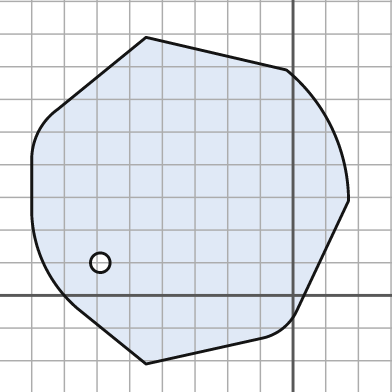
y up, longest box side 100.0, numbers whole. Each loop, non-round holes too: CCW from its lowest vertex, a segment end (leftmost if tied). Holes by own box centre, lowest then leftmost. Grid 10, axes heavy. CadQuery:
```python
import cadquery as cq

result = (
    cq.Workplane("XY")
    .moveTo(-45.0, -21.0)
    .lineTo(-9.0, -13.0)
    .threePointArc((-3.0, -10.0), (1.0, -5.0))
    .lineTo(17.0, 29.0)
    .threePointArc((12.0, 51.0), (-2.0, 69.0))
    .lineTo(-45.0, 79.0)
    .lineTo(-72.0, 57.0)
    .threePointArc((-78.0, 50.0), (-80.0, 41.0))
    .lineTo(-80.0, 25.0)
    .threePointArc((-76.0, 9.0), (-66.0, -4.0))
    .close()
    .moveTo(-59.0, 10.0)
    .circle(3.0)
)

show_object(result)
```